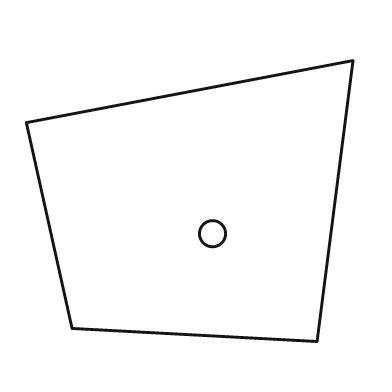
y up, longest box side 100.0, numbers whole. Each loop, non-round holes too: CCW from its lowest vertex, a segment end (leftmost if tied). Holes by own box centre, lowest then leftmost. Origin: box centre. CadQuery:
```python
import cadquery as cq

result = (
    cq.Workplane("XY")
    .moveTo(39.0, -43.0)
    .lineTo(50.0, 43.0)
    .lineTo(-50.0, 24.0)
    .lineTo(-36.0, -39.0)
    .close()
    .moveTo(7.0, -10.0)
    .circle(4.0)
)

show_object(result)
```